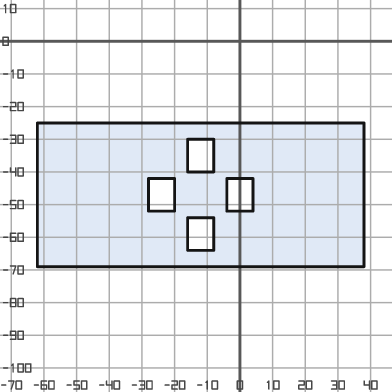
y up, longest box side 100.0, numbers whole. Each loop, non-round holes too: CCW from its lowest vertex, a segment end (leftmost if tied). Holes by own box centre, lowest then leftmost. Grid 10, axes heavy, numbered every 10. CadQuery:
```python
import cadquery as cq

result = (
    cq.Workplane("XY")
    .moveTo(-62.0, -69.0)
    .lineTo(38.0, -69.0)
    .lineTo(38.0, -25.0)
    .lineTo(-62.0, -25.0)
    .close()
    .moveTo(-16.0, -64.0)
    .lineTo(-8.0, -64.0)
    .lineTo(-8.0, -54.0)
    .lineTo(-16.0, -54.0)
    .close()
    .moveTo(-28.0, -52.0)
    .lineTo(-20.0, -52.0)
    .lineTo(-20.0, -42.0)
    .lineTo(-28.0, -42.0)
    .close()
    .moveTo(-4.0, -52.0)
    .lineTo(4.0, -52.0)
    .lineTo(4.0, -42.0)
    .lineTo(-4.0, -42.0)
    .close()
    .moveTo(-16.0, -40.0)
    .lineTo(-8.0, -40.0)
    .lineTo(-8.0, -30.0)
    .lineTo(-16.0, -30.0)
    .close()
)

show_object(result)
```